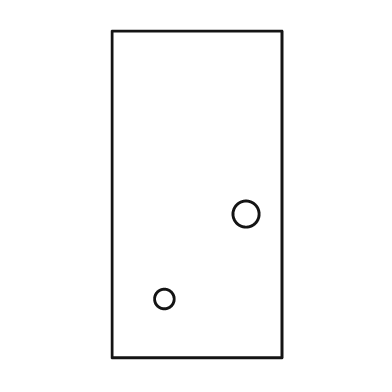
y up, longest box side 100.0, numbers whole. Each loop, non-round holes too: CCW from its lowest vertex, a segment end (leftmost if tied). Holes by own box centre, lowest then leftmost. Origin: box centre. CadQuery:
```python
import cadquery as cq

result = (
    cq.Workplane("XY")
    .moveTo(-26.0, -50.0)
    .lineTo(26.0, -50.0)
    .lineTo(26.0, 50.0)
    .lineTo(-26.0, 50.0)
    .close()
    .moveTo(-10.0, -32.0)
    .circle(3.0)
    .moveTo(15.0, -6.0)
    .circle(4.0)
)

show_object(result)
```